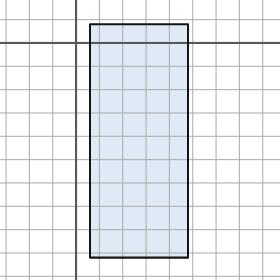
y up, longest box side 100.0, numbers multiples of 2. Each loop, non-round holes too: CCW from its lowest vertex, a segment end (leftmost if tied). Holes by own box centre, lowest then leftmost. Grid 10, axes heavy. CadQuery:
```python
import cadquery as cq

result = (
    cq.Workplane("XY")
    .moveTo(6.0, -92.0)
    .lineTo(48.0, -92.0)
    .lineTo(48.0, 8.0)
    .lineTo(6.0, 8.0)
    .close()
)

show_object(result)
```